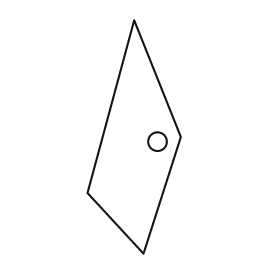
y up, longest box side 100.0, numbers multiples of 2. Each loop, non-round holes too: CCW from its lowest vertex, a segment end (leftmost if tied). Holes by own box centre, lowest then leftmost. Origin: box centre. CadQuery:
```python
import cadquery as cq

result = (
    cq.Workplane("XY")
    .moveTo(4.0, -50.0)
    .lineTo(20.0, 0.0)
    .lineTo(0.0, 50.0)
    .lineTo(-20.0, -24.0)
    .close()
    .moveTo(10.0, -2.0)
    .circle(4.0)
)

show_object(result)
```